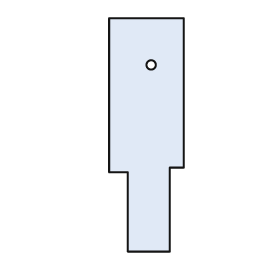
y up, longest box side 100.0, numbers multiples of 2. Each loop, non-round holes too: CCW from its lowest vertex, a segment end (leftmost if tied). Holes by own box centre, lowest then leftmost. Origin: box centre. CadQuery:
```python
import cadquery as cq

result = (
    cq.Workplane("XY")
    .moveTo(-8.0, -50.0)
    .lineTo(10.0, -50.0)
    .lineTo(10.0, -14.0)
    .lineTo(16.0, -14.0)
    .lineTo(16.0, 50.0)
    .lineTo(-16.0, 50.0)
    .lineTo(-16.0, -16.0)
    .lineTo(-8.0, -16.0)
    .close()
    .moveTo(2.0, 30.0)
    .circle(2.0)
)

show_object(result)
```